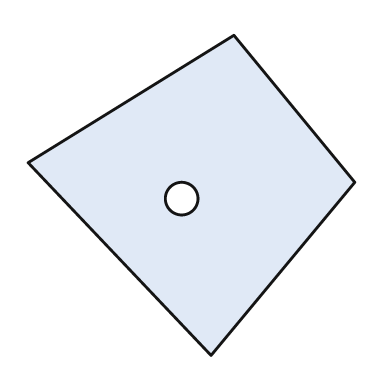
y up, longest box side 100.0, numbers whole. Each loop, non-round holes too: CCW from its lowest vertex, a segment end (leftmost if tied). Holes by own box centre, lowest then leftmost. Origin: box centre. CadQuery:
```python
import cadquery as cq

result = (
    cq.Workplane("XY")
    .moveTo(6.0, -49.0)
    .lineTo(50.0, 4.0)
    .lineTo(13.0, 49.0)
    .lineTo(-50.0, 10.0)
    .close()
    .moveTo(-3.0, -1.0)
    .circle(5.0)
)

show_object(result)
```